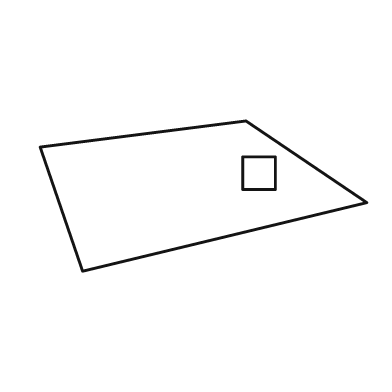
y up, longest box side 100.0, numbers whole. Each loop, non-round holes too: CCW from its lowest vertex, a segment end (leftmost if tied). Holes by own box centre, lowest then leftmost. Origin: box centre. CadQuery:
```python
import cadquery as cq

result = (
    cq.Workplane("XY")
    .moveTo(-37.0, -23.0)
    .lineTo(50.0, -2.0)
    .lineTo(13.0, 23.0)
    .lineTo(-50.0, 15.0)
    .close()
    .moveTo(12.0, 2.0)
    .lineTo(22.0, 2.0)
    .lineTo(22.0, 12.0)
    .lineTo(12.0, 12.0)
    .close()
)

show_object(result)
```